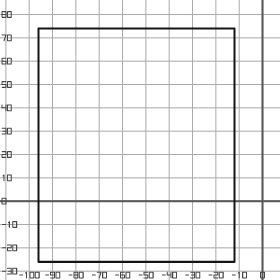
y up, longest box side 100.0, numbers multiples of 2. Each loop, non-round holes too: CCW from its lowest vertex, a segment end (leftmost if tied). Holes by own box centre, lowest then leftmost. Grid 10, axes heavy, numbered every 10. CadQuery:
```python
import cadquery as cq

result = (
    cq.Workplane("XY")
    .moveTo(-96.0, -26.0)
    .lineTo(-12.0, -26.0)
    .lineTo(-12.0, 74.0)
    .lineTo(-96.0, 74.0)
    .close()
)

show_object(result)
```